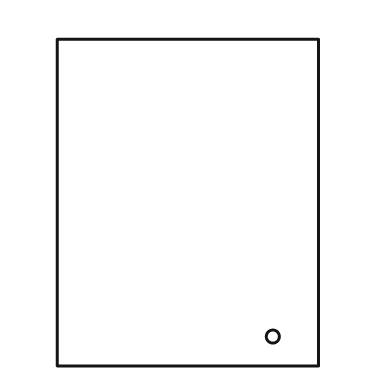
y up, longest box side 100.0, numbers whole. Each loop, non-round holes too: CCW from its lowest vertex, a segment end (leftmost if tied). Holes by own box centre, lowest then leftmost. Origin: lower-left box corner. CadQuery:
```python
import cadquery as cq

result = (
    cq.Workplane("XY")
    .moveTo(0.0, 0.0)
    .lineTo(80.0, 0.0)
    .lineTo(80.0, 100.0)
    .lineTo(0.0, 100.0)
    .close()
    .moveTo(66.0, 9.0)
    .circle(2.0)
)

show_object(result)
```